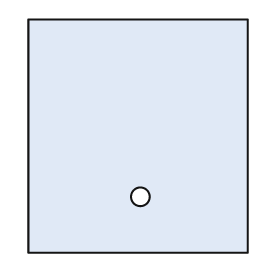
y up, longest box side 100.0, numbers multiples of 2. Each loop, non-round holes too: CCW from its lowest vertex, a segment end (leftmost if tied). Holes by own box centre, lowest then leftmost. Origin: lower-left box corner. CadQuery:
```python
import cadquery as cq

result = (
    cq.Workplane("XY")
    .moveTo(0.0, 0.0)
    .lineTo(94.0, 0.0)
    .lineTo(94.0, 100.0)
    .lineTo(0.0, 100.0)
    .close()
    .moveTo(48.0, 24.0)
    .circle(4.0)
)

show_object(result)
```